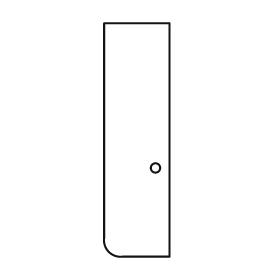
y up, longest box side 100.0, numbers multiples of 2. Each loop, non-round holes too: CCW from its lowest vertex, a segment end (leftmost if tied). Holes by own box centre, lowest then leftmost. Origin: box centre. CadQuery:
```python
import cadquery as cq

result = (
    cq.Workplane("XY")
    .moveTo(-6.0, -50.0)
    .lineTo(14.0, -50.0)
    .lineTo(14.0, 50.0)
    .lineTo(-14.0, 50.0)
    .lineTo(-14.0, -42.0)
    .threePointArc((-12.0, -48.0), (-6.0, -50.0))
    .close()
    .moveTo(8.0, -12.0)
    .circle(2.0)
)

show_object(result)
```